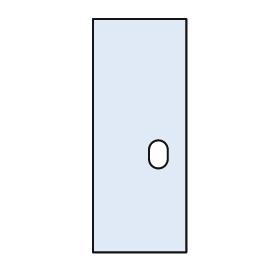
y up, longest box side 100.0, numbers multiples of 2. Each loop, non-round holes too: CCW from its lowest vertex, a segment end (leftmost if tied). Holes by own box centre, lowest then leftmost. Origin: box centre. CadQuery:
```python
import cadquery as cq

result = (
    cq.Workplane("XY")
    .moveTo(-20.0, -50.0)
    .lineTo(20.0, -50.0)
    .lineTo(20.0, 50.0)
    .lineTo(-20.0, 50.0)
    .close()
    .moveTo(4.0, -10.0)
    .threePointArc((8.0, -14.0), (12.0, -10.0))
    .lineTo(12.0, -6.0)
    .threePointArc((8.0, -2.0), (4.0, -6.0))
    .close()
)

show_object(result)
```